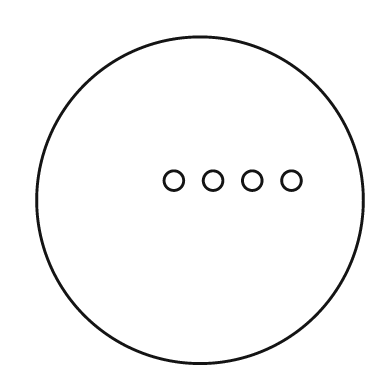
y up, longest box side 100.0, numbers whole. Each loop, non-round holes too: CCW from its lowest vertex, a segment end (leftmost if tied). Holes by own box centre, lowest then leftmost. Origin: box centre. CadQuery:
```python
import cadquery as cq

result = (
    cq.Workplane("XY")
    .moveTo(0.0, 0.0)
    .circle(50.0)
    .moveTo(-8.0, 6.0)
    .circle(3.0)
    .moveTo(4.0, 6.0)
    .circle(3.0)
    .moveTo(16.0, 6.0)
    .circle(3.0)
    .moveTo(28.0, 6.0)
    .circle(3.0)
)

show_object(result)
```